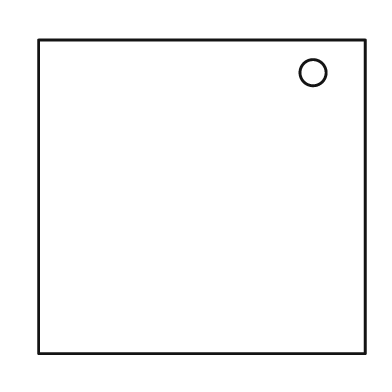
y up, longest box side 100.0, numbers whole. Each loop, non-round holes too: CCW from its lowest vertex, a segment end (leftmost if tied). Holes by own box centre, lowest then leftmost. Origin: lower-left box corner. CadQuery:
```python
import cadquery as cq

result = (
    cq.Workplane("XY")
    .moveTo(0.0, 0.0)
    .lineTo(100.0, 0.0)
    .lineTo(100.0, 96.0)
    .lineTo(0.0, 96.0)
    .close()
    .moveTo(84.0, 86.0)
    .circle(4.0)
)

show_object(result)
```